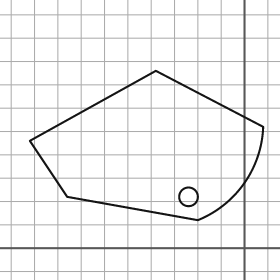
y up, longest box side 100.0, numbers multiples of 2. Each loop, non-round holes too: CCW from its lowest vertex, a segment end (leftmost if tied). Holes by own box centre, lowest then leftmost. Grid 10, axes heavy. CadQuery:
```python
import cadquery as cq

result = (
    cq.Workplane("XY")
    .moveTo(-20.0, 12.0)
    .threePointArc((0.0, 28.0), (8.0, 52.0))
    .lineTo(-38.0, 76.0)
    .lineTo(-92.0, 46.0)
    .lineTo(-76.0, 22.0)
    .close()
    .moveTo(-24.0, 22.0)
    .circle(4.0)
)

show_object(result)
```